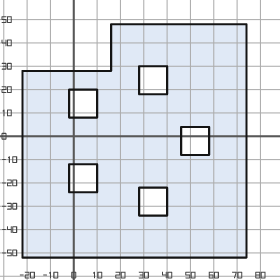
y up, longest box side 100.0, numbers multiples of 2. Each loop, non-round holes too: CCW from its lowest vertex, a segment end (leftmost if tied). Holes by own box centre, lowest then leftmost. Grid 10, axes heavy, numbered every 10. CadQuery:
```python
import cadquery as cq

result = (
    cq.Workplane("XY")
    .moveTo(-22.0, -52.0)
    .lineTo(74.0, -52.0)
    .lineTo(74.0, 48.0)
    .lineTo(16.0, 48.0)
    .lineTo(16.0, 28.0)
    .lineTo(-22.0, 28.0)
    .close()
    .moveTo(28.0, -34.0)
    .lineTo(40.0, -34.0)
    .lineTo(40.0, -22.0)
    .lineTo(28.0, -22.0)
    .close()
    .moveTo(-2.0, -24.0)
    .lineTo(10.0, -24.0)
    .lineTo(10.0, -12.0)
    .lineTo(-2.0, -12.0)
    .close()
    .moveTo(46.0, -8.0)
    .lineTo(58.0, -8.0)
    .lineTo(58.0, 4.0)
    .lineTo(46.0, 4.0)
    .close()
    .moveTo(-2.0, 8.0)
    .lineTo(10.0, 8.0)
    .lineTo(10.0, 20.0)
    .lineTo(-2.0, 20.0)
    .close()
    .moveTo(28.0, 18.0)
    .lineTo(40.0, 18.0)
    .lineTo(40.0, 30.0)
    .lineTo(28.0, 30.0)
    .close()
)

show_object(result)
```